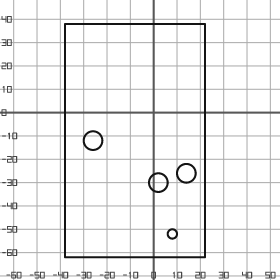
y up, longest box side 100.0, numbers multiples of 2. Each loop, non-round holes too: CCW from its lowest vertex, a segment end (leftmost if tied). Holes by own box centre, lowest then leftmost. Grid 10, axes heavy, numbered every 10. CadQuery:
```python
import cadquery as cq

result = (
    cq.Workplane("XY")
    .moveTo(-38.0, -62.0)
    .lineTo(22.0, -62.0)
    .lineTo(22.0, 38.0)
    .lineTo(-38.0, 38.0)
    .close()
    .moveTo(8.0, -52.0)
    .circle(2.0)
    .moveTo(2.0, -30.0)
    .circle(4.0)
    .moveTo(14.0, -26.0)
    .circle(4.0)
    .moveTo(-26.0, -12.0)
    .circle(4.0)
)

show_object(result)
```